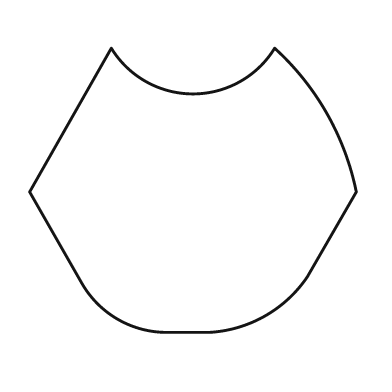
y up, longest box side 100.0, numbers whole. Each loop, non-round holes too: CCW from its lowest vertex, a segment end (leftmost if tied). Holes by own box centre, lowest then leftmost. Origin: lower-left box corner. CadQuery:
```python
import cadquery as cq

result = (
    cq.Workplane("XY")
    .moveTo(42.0, 0.0)
    .lineTo(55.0, 0.0)
    .threePointArc((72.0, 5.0), (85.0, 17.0))
    .lineTo(100.0, 43.0)
    .threePointArc((91.0, 67.0), (75.0, 87.0))
    .threePointArc((50.0, 73.0), (25.0, 87.0))
    .lineTo(0.0, 43.0)
    .lineTo(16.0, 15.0)
    .threePointArc((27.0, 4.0), (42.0, 0.0))
    .close()
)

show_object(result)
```